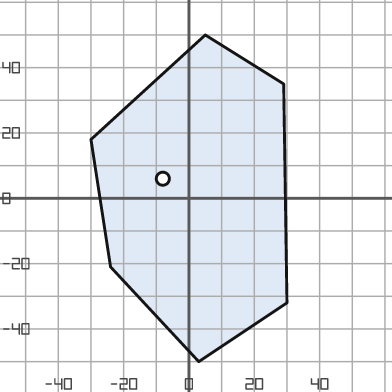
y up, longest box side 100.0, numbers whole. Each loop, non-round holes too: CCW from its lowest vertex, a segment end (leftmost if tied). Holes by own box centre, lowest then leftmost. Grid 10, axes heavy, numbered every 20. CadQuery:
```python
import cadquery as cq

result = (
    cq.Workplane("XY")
    .moveTo(3.0, -50.0)
    .lineTo(30.0, -32.0)
    .lineTo(29.0, 35.0)
    .lineTo(5.0, 50.0)
    .lineTo(-30.0, 18.0)
    .lineTo(-24.0, -21.0)
    .close()
    .moveTo(-8.0, 6.0)
    .circle(2.0)
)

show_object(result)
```